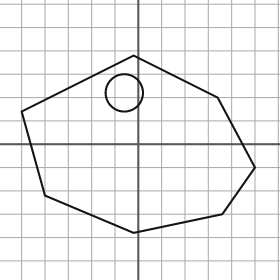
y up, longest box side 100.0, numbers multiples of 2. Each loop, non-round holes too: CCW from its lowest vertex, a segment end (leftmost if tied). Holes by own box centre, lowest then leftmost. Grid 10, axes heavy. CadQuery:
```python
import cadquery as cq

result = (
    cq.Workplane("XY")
    .moveTo(-2.0, -38.0)
    .lineTo(36.0, -30.0)
    .lineTo(50.0, -10.0)
    .lineTo(34.0, 20.0)
    .lineTo(-2.0, 38.0)
    .lineTo(-50.0, 14.0)
    .lineTo(-40.0, -22.0)
    .close()
    .moveTo(-6.0, 22.0)
    .circle(8.0)
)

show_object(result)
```